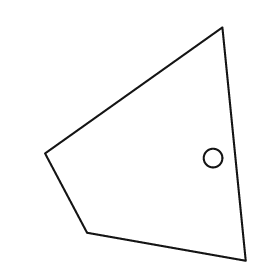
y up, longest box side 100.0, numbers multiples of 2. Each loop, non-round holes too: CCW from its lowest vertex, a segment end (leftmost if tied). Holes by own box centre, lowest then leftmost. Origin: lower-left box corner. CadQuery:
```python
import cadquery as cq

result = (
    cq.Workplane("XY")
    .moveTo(86.0, 0.0)
    .lineTo(76.0, 100.0)
    .lineTo(0.0, 46.0)
    .lineTo(18.0, 12.0)
    .close()
    .moveTo(72.0, 44.0)
    .circle(4.0)
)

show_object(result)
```